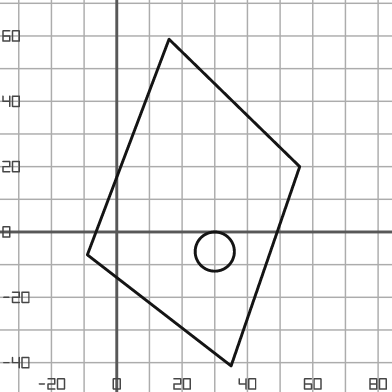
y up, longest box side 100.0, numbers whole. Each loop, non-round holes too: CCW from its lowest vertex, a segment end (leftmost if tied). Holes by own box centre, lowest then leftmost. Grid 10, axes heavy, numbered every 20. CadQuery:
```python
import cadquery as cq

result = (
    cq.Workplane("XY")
    .moveTo(35.0, -41.0)
    .lineTo(56.0, 20.0)
    .lineTo(16.0, 59.0)
    .lineTo(-9.0, -7.0)
    .close()
    .moveTo(30.0, -6.0)
    .circle(6.0)
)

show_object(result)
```